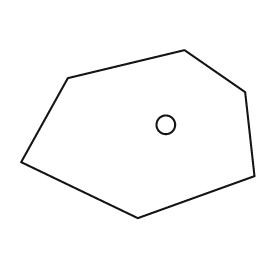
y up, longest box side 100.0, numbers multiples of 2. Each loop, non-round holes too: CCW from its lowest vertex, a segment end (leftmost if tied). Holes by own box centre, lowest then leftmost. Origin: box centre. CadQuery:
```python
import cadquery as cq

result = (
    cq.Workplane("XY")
    .moveTo(0.0, -36.0)
    .lineTo(50.0, -18.0)
    .lineTo(46.0, 18.0)
    .lineTo(20.0, 36.0)
    .lineTo(-30.0, 24.0)
    .lineTo(-50.0, -12.0)
    .close()
    .moveTo(12.0, 4.0)
    .circle(4.0)
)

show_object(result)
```